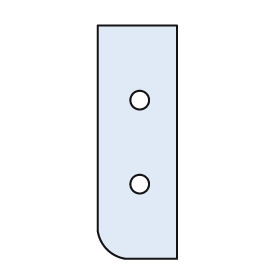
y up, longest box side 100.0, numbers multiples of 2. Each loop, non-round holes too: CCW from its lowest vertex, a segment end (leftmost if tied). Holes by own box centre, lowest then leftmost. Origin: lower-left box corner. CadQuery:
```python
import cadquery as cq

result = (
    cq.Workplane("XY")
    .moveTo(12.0, 0.0)
    .lineTo(34.0, 0.0)
    .lineTo(34.0, 100.0)
    .lineTo(0.0, 100.0)
    .lineTo(0.0, 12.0)
    .threePointArc((4.0, 4.0), (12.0, 0.0))
    .close()
    .moveTo(18.0, 32.0)
    .circle(4.0)
    .moveTo(18.0, 68.0)
    .circle(4.0)
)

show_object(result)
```